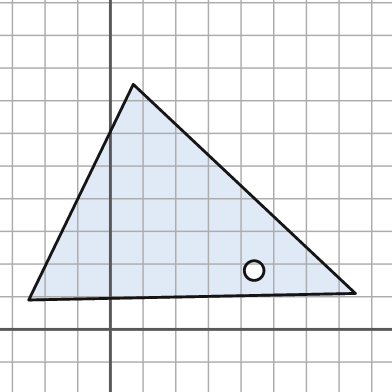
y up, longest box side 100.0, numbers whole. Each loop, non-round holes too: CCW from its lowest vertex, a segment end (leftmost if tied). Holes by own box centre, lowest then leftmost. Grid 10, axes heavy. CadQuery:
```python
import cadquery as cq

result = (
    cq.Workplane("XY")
    .moveTo(-25.0, 9.0)
    .lineTo(75.0, 11.0)
    .lineTo(7.0, 75.0)
    .close()
    .moveTo(44.0, 18.0)
    .circle(3.0)
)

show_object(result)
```